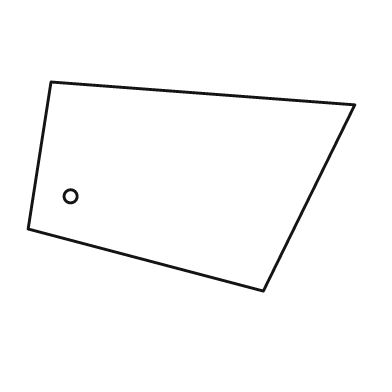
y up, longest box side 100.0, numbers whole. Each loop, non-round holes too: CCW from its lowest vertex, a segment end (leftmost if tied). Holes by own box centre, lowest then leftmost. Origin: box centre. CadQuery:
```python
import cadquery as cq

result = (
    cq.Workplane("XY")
    .moveTo(22.0, -32.0)
    .lineTo(50.0, 25.0)
    .lineTo(-43.0, 32.0)
    .lineTo(-50.0, -13.0)
    .close()
    .moveTo(-37.0, -3.0)
    .circle(2.0)
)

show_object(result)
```